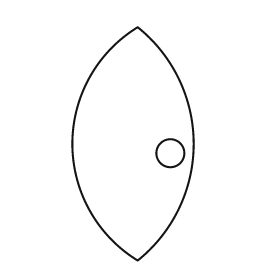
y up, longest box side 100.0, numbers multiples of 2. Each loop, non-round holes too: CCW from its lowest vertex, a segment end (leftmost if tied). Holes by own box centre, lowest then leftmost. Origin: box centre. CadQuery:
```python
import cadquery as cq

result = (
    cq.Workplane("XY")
    .moveTo(2.0, -50.0)
    .threePointArc((26.0, 0.0), (2.0, 50.0))
    .threePointArc((-26.0, 0.0), (2.0, -50.0))
    .close()
    .moveTo(16.0, -4.0)
    .circle(6.0)
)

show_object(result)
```